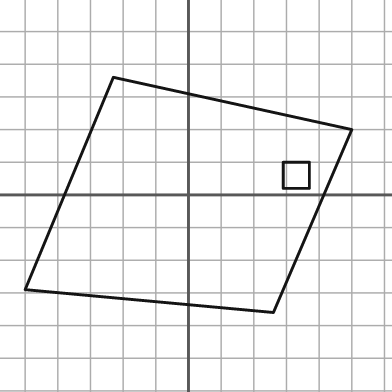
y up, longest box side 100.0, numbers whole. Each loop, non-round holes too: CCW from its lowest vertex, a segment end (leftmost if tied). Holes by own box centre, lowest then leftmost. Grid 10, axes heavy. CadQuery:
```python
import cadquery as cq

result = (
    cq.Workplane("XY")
    .moveTo(26.0, -36.0)
    .lineTo(50.0, 20.0)
    .lineTo(-23.0, 36.0)
    .lineTo(-50.0, -29.0)
    .close()
    .moveTo(29.0, 2.0)
    .lineTo(37.0, 2.0)
    .lineTo(37.0, 10.0)
    .lineTo(29.0, 10.0)
    .close()
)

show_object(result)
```